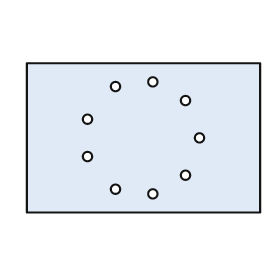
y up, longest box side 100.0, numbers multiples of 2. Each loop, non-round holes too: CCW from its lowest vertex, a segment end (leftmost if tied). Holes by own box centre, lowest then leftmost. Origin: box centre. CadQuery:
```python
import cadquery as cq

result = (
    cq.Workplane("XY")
    .moveTo(-50.0, -32.0)
    .lineTo(50.0, -32.0)
    .lineTo(50.0, 32.0)
    .lineTo(-50.0, 32.0)
    .close()
    .moveTo(4.0, -24.0)
    .circle(2.0)
    .moveTo(-12.0, -22.0)
    .circle(2.0)
    .moveTo(18.0, -16.0)
    .circle(2.0)
    .moveTo(-24.0, -8.0)
    .circle(2.0)
    .moveTo(24.0, 0.0)
    .circle(2.0)
    .moveTo(-24.0, 8.0)
    .circle(2.0)
    .moveTo(18.0, 16.0)
    .circle(2.0)
    .moveTo(-12.0, 22.0)
    .circle(2.0)
    .moveTo(4.0, 24.0)
    .circle(2.0)
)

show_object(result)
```